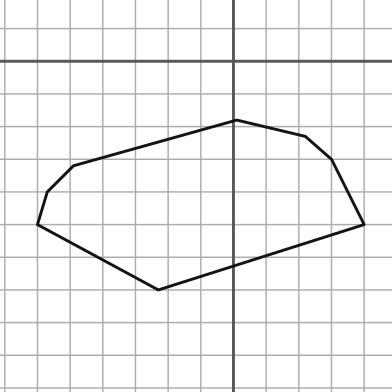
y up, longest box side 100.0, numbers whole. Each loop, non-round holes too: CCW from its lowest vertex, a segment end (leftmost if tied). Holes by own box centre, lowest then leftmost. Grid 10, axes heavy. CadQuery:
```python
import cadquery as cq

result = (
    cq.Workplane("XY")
    .moveTo(-23.0, -70.0)
    .lineTo(40.0, -50.0)
    .lineTo(30.0, -30.0)
    .lineTo(22.0, -23.0)
    .lineTo(1.0, -18.0)
    .lineTo(-49.0, -32.0)
    .lineTo(-57.0, -40.0)
    .lineTo(-60.0, -50.0)
    .close()
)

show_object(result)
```